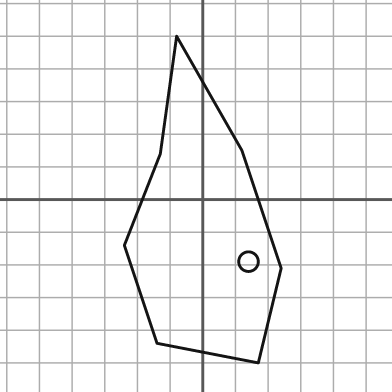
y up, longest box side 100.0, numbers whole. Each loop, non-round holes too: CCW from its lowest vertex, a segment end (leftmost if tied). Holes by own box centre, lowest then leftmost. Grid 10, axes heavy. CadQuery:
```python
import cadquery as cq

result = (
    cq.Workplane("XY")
    .moveTo(17.0, -50.0)
    .lineTo(24.0, -21.0)
    .lineTo(12.0, 15.0)
    .lineTo(-8.0, 50.0)
    .lineTo(-13.0, 14.0)
    .lineTo(-24.0, -14.0)
    .lineTo(-14.0, -44.0)
    .close()
    .moveTo(14.0, -19.0)
    .circle(3.0)
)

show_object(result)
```